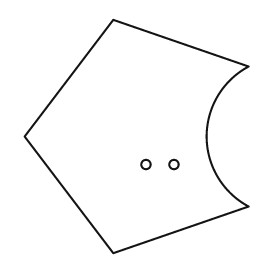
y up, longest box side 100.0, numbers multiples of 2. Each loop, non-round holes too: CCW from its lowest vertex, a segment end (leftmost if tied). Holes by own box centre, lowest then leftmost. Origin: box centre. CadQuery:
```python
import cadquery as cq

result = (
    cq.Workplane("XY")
    .moveTo(-10.0, -50.0)
    .lineTo(48.0, -30.0)
    .threePointArc((30.0, 0.0), (48.0, 30.0))
    .lineTo(-10.0, 50.0)
    .lineTo(-48.0, 0.0)
    .close()
    .moveTo(4.0, -12.0)
    .circle(2.0)
    .moveTo(16.0, -12.0)
    .circle(2.0)
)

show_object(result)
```